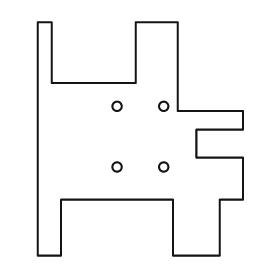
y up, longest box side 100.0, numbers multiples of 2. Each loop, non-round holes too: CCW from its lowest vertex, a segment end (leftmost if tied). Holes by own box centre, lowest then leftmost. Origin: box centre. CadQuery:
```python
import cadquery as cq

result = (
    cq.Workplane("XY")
    .moveTo(-44.0, -50.0)
    .lineTo(-34.0, -50.0)
    .lineTo(-34.0, -26.0)
    .lineTo(14.0, -26.0)
    .lineTo(14.0, -50.0)
    .lineTo(34.0, -50.0)
    .lineTo(34.0, -26.0)
    .lineTo(44.0, -26.0)
    .lineTo(44.0, -8.0)
    .lineTo(24.0, -8.0)
    .lineTo(24.0, 4.0)
    .lineTo(44.0, 4.0)
    .lineTo(44.0, 12.0)
    .lineTo(16.0, 12.0)
    .lineTo(16.0, 50.0)
    .lineTo(-2.0, 50.0)
    .lineTo(-2.0, 24.0)
    .lineTo(-38.0, 24.0)
    .lineTo(-38.0, 50.0)
    .lineTo(-44.0, 50.0)
    .close()
    .moveTo(-10.0, -12.0)
    .circle(2.0)
    .moveTo(10.0, -12.0)
    .circle(2.0)
    .moveTo(-10.0, 14.0)
    .circle(2.0)
    .moveTo(10.0, 14.0)
    .circle(2.0)
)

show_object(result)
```